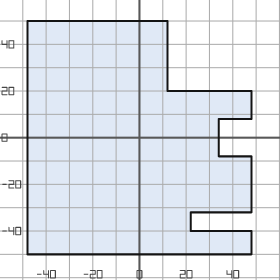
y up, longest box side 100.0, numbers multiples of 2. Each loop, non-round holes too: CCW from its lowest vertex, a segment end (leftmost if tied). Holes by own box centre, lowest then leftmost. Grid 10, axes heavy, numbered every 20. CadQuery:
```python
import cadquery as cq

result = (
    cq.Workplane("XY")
    .moveTo(-48.0, -50.0)
    .lineTo(48.0, -50.0)
    .lineTo(48.0, -40.0)
    .lineTo(22.0, -40.0)
    .lineTo(22.0, -32.0)
    .lineTo(48.0, -32.0)
    .lineTo(48.0, -8.0)
    .lineTo(34.0, -8.0)
    .lineTo(34.0, 8.0)
    .lineTo(48.0, 8.0)
    .lineTo(48.0, 20.0)
    .lineTo(12.0, 20.0)
    .lineTo(12.0, 50.0)
    .lineTo(-48.0, 50.0)
    .close()
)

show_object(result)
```